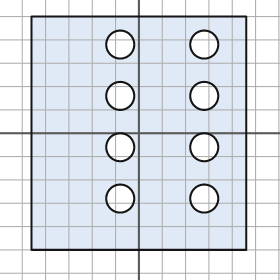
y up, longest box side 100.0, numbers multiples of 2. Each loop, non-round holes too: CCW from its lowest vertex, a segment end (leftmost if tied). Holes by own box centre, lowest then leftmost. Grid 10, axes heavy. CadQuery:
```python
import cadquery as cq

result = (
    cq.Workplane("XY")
    .moveTo(-46.0, -50.0)
    .lineTo(46.0, -50.0)
    .lineTo(46.0, 50.0)
    .lineTo(-46.0, 50.0)
    .close()
    .moveTo(-8.0, -28.0)
    .circle(6.0)
    .moveTo(28.0, -28.0)
    .circle(6.0)
    .moveTo(-8.0, -6.0)
    .circle(6.0)
    .moveTo(28.0, -6.0)
    .circle(6.0)
    .moveTo(-8.0, 16.0)
    .circle(6.0)
    .moveTo(28.0, 16.0)
    .circle(6.0)
    .moveTo(-8.0, 38.0)
    .circle(6.0)
    .moveTo(28.0, 38.0)
    .circle(6.0)
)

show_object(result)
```